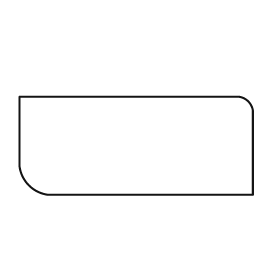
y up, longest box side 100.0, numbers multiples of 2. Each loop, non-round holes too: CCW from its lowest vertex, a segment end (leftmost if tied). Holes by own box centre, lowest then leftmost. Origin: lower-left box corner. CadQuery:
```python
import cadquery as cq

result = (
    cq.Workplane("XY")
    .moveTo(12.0, 0.0)
    .lineTo(100.0, 0.0)
    .lineTo(100.0, 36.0)
    .threePointArc((98.0, 40.0), (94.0, 42.0))
    .lineTo(0.0, 42.0)
    .lineTo(0.0, 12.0)
    .threePointArc((4.0, 4.0), (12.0, 0.0))
    .close()
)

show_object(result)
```